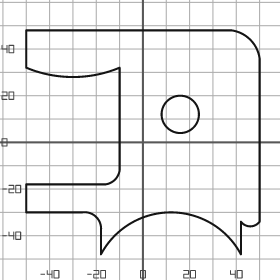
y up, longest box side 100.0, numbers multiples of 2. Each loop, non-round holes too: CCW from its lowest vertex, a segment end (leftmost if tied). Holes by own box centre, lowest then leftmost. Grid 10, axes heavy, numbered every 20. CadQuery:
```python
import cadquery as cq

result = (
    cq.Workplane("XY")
    .moveTo(-18.0, -48.0)
    .threePointArc((12.0, -30.0), (42.0, -48.0))
    .lineTo(42.0, -34.0)
    .threePointArc((46.0, -36.0), (50.0, -34.0))
    .lineTo(50.0, 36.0)
    .threePointArc((46.0, 44.0), (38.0, 48.0))
    .lineTo(-50.0, 48.0)
    .lineTo(-50.0, 32.0)
    .threePointArc((-30.0, 28.0), (-10.0, 32.0))
    .lineTo(-10.0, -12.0)
    .threePointArc((-12.0, -16.0), (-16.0, -18.0))
    .lineTo(-50.0, -18.0)
    .lineTo(-50.0, -30.0)
    .lineTo(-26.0, -30.0)
    .threePointArc((-20.0, -32.0), (-18.0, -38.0))
    .close()
    .moveTo(16.0, 12.0)
    .circle(8.0)
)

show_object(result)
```